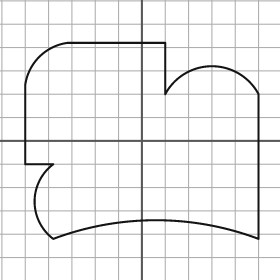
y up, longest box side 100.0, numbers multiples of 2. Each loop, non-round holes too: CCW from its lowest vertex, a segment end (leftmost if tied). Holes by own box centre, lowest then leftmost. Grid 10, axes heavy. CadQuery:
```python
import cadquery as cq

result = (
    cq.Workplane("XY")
    .moveTo(-38.0, -42.0)
    .threePointArc((6.0, -34.0), (50.0, -42.0))
    .lineTo(50.0, 20.0)
    .threePointArc((30.0, 32.0), (10.0, 20.0))
    .lineTo(10.0, 42.0)
    .lineTo(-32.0, 42.0)
    .threePointArc((-44.0, 36.0), (-50.0, 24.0))
    .lineTo(-50.0, -10.0)
    .lineTo(-38.0, -10.0)
    .threePointArc((-46.0, -26.0), (-38.0, -42.0))
    .close()
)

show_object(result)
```